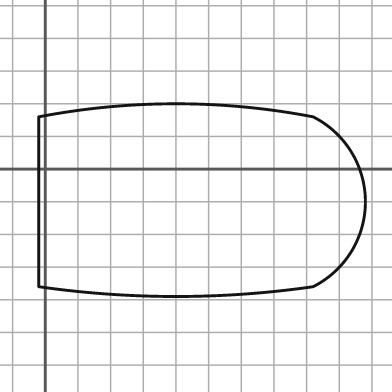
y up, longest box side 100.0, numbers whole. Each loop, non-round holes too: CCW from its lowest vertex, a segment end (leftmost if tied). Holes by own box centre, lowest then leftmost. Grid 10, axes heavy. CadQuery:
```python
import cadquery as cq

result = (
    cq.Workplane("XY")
    .moveTo(-2.0, -36.0)
    .threePointArc((40.0, -39.0), (82.0, -36.0))
    .threePointArc((98.0, -10.0), (82.0, 16.0))
    .threePointArc((40.0, 20.0), (-2.0, 16.0))
    .close()
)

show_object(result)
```